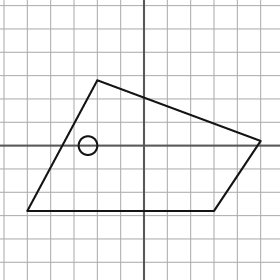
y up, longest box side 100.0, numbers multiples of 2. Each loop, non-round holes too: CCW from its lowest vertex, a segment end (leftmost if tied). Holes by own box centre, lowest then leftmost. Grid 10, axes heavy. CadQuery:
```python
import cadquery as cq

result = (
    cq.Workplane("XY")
    .moveTo(-50.0, -28.0)
    .lineTo(30.0, -28.0)
    .lineTo(50.0, 2.0)
    .lineTo(-20.0, 28.0)
    .close()
    .moveTo(-24.0, 0.0)
    .circle(4.0)
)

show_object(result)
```